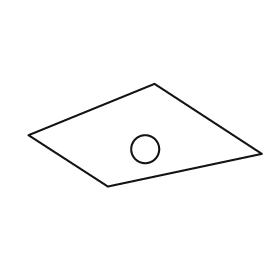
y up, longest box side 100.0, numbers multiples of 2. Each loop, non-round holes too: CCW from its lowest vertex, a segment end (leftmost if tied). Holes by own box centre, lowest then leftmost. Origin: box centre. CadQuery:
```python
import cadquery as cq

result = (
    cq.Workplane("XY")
    .moveTo(-16.0, -22.0)
    .lineTo(50.0, -8.0)
    .lineTo(4.0, 22.0)
    .lineTo(-50.0, 0.0)
    .close()
    .moveTo(0.0, -6.0)
    .circle(6.0)
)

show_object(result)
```